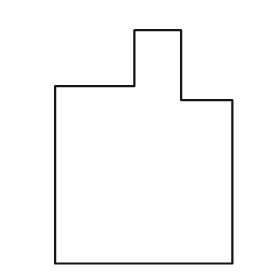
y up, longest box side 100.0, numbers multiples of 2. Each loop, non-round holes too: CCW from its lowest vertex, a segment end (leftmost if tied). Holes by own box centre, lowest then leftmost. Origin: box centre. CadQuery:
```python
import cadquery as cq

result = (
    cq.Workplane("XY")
    .moveTo(-38.0, -50.0)
    .lineTo(38.0, -50.0)
    .lineTo(38.0, 20.0)
    .lineTo(16.0, 20.0)
    .lineTo(16.0, 50.0)
    .lineTo(-4.0, 50.0)
    .lineTo(-4.0, 26.0)
    .lineTo(-38.0, 26.0)
    .close()
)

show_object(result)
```